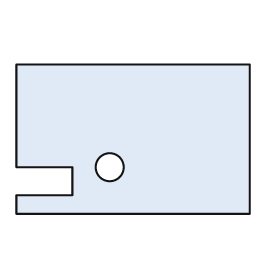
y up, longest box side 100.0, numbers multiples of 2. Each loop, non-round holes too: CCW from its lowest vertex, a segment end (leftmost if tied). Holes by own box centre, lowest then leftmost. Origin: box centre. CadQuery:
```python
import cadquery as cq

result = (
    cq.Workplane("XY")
    .moveTo(-50.0, -32.0)
    .lineTo(50.0, -32.0)
    .lineTo(50.0, 32.0)
    .lineTo(-50.0, 32.0)
    .lineTo(-50.0, -12.0)
    .lineTo(-26.0, -12.0)
    .lineTo(-26.0, -24.0)
    .lineTo(-50.0, -24.0)
    .close()
    .moveTo(-10.0, -12.0)
    .circle(6.0)
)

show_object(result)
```